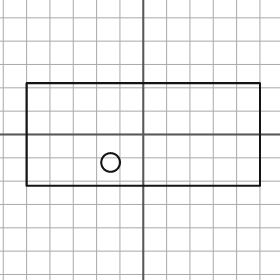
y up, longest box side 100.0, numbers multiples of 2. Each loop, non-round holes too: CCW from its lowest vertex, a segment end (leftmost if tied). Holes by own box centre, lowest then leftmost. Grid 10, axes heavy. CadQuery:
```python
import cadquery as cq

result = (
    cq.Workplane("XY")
    .moveTo(-50.0, -22.0)
    .lineTo(50.0, -22.0)
    .lineTo(50.0, 22.0)
    .lineTo(-50.0, 22.0)
    .close()
    .moveTo(-14.0, -12.0)
    .circle(4.0)
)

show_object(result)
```